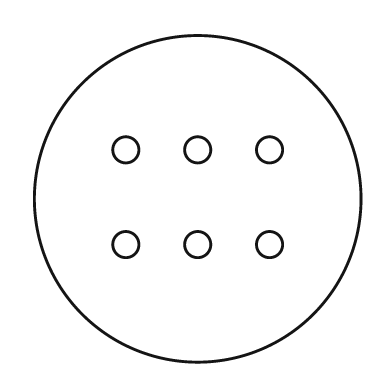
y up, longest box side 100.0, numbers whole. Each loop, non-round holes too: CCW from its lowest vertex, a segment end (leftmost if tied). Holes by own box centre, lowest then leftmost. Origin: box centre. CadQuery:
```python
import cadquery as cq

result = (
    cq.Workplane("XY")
    .moveTo(0.0, 0.0)
    .circle(50.0)
    .moveTo(-22.0, -14.0)
    .circle(4.0)
    .moveTo(0.0, -14.0)
    .circle(4.0)
    .moveTo(22.0, -14.0)
    .circle(4.0)
    .moveTo(-22.0, 15.0)
    .circle(4.0)
    .moveTo(0.0, 15.0)
    .circle(4.0)
    .moveTo(22.0, 15.0)
    .circle(4.0)
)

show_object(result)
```